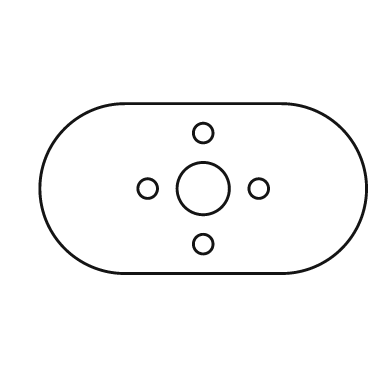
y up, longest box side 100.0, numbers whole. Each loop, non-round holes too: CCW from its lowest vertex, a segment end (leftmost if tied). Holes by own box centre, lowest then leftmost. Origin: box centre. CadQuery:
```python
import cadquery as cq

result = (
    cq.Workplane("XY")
    .moveTo(-24.0, -26.0)
    .lineTo(24.0, -26.0)
    .threePointArc((50.0, 0.0), (24.0, 26.0))
    .lineTo(-24.0, 26.0)
    .threePointArc((-50.0, 0.0), (-24.0, -26.0))
    .close()
    .moveTo(0.0, -17.0)
    .circle(3.0)
    .moveTo(-17.0, 0.0)
    .circle(3.0)
    .moveTo(0.0, 0.0)
    .circle(8.0)
    .moveTo(17.0, 0.0)
    .circle(3.0)
    .moveTo(0.0, 17.0)
    .circle(3.0)
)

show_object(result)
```